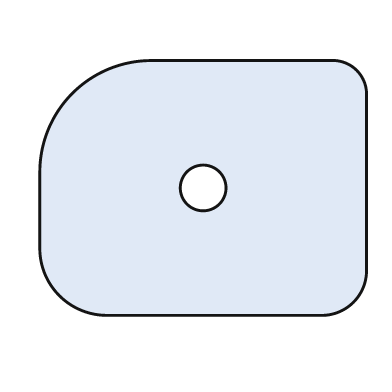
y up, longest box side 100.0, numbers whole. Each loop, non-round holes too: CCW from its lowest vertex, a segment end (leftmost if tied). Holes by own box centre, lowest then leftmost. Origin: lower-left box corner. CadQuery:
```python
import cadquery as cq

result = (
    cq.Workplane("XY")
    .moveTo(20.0, 0.0)
    .lineTo(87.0, 0.0)
    .threePointArc((96.0, 4.0), (100.0, 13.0))
    .lineTo(100.0, 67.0)
    .threePointArc((97.0, 75.0), (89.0, 78.0))
    .lineTo(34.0, 78.0)
    .threePointArc((10.0, 68.0), (0.0, 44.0))
    .lineTo(0.0, 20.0)
    .threePointArc((6.0, 6.0), (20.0, 0.0))
    .close()
    .moveTo(50.0, 39.0)
    .circle(7.0)
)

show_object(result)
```